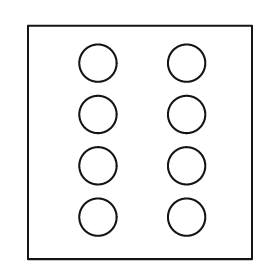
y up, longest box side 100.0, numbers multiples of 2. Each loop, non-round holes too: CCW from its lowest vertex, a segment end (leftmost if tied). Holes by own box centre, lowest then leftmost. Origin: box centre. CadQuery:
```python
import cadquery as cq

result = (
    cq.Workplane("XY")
    .moveTo(-48.0, -50.0)
    .lineTo(48.0, -50.0)
    .lineTo(48.0, 50.0)
    .lineTo(-48.0, 50.0)
    .close()
    .moveTo(-18.0, -32.0)
    .circle(8.0)
    .moveTo(20.0, -32.0)
    .circle(8.0)
    .moveTo(-18.0, -10.0)
    .circle(8.0)
    .moveTo(20.0, -10.0)
    .circle(8.0)
    .moveTo(-18.0, 12.0)
    .circle(8.0)
    .moveTo(20.0, 12.0)
    .circle(8.0)
    .moveTo(-18.0, 34.0)
    .circle(8.0)
    .moveTo(20.0, 34.0)
    .circle(8.0)
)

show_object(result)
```